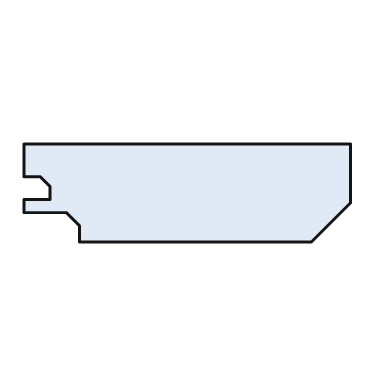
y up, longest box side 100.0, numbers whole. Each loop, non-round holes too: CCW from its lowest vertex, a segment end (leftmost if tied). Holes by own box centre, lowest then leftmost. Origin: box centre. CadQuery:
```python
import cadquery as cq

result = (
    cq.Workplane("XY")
    .moveTo(-33.0, -15.0)
    .lineTo(38.0, -15.0)
    .lineTo(50.0, -3.0)
    .lineTo(50.0, 15.0)
    .lineTo(-50.0, 15.0)
    .lineTo(-50.0, 5.0)
    .lineTo(-45.0, 5.0)
    .lineTo(-42.0, 2.0)
    .lineTo(-42.0, -2.0)
    .lineTo(-50.0, -2.0)
    .lineTo(-50.0, -6.0)
    .lineTo(-37.0, -6.0)
    .lineTo(-33.0, -10.0)
    .close()
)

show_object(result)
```